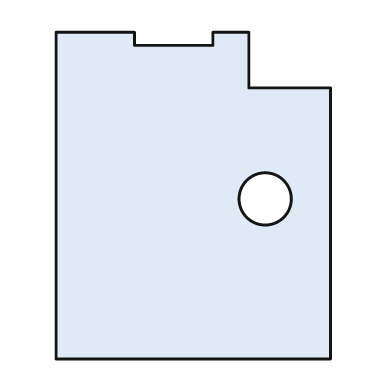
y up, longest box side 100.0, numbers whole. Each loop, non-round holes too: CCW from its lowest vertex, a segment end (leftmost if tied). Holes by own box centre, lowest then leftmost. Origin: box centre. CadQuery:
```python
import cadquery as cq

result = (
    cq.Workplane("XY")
    .moveTo(-42.0, -50.0)
    .lineTo(42.0, -50.0)
    .lineTo(42.0, 33.0)
    .lineTo(17.0, 33.0)
    .lineTo(17.0, 50.0)
    .lineTo(6.0, 50.0)
    .lineTo(6.0, 46.0)
    .lineTo(-18.0, 46.0)
    .lineTo(-18.0, 50.0)
    .lineTo(-42.0, 50.0)
    .close()
    .moveTo(22.0, -1.0)
    .circle(8.0)
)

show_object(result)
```